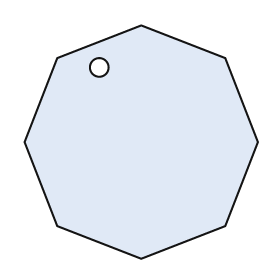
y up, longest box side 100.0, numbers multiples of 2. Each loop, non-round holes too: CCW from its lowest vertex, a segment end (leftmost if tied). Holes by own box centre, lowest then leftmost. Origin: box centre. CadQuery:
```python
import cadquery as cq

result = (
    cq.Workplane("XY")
    .moveTo(0.0, -50.0)
    .lineTo(36.0, -36.0)
    .lineTo(50.0, 0.0)
    .lineTo(36.0, 36.0)
    .lineTo(0.0, 50.0)
    .lineTo(-36.0, 36.0)
    .lineTo(-50.0, 0.0)
    .lineTo(-36.0, -36.0)
    .close()
    .moveTo(-18.0, 32.0)
    .circle(4.0)
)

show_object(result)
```